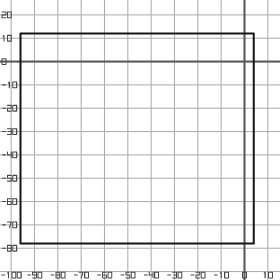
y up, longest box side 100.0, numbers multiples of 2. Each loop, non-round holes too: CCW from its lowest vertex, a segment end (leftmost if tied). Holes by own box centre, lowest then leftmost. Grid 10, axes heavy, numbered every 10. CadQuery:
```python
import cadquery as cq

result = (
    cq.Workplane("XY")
    .moveTo(-96.0, -78.0)
    .lineTo(4.0, -78.0)
    .lineTo(4.0, 12.0)
    .lineTo(-96.0, 12.0)
    .close()
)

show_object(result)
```